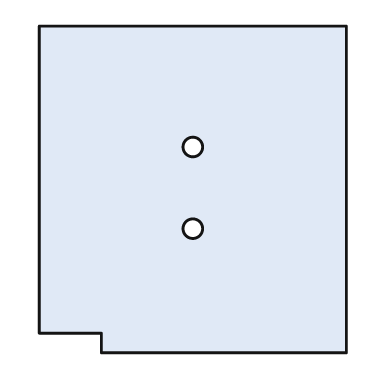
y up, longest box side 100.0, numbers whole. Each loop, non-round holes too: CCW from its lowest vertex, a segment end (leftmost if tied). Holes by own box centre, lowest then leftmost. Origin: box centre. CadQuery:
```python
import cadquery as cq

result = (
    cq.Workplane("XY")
    .moveTo(-28.0, -50.0)
    .lineTo(47.0, -50.0)
    .lineTo(47.0, 50.0)
    .lineTo(-47.0, 50.0)
    .lineTo(-47.0, -44.0)
    .lineTo(-28.0, -44.0)
    .close()
    .moveTo(0.0, -12.0)
    .circle(3.0)
    .moveTo(0.0, 13.0)
    .circle(3.0)
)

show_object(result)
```